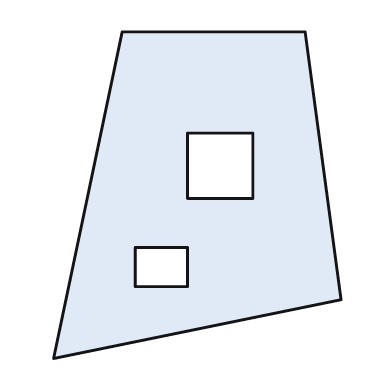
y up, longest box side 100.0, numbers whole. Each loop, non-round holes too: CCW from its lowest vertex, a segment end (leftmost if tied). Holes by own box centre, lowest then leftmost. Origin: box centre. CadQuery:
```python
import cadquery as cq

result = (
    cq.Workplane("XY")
    .moveTo(-44.0, -50.0)
    .lineTo(44.0, -32.0)
    .lineTo(33.0, 50.0)
    .lineTo(-23.0, 50.0)
    .close()
    .moveTo(-19.0, -28.0)
    .lineTo(-3.0, -28.0)
    .lineTo(-3.0, -16.0)
    .lineTo(-19.0, -16.0)
    .close()
    .moveTo(-3.0, -1.0)
    .lineTo(17.0, -1.0)
    .lineTo(17.0, 19.0)
    .lineTo(-3.0, 19.0)
    .close()
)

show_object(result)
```